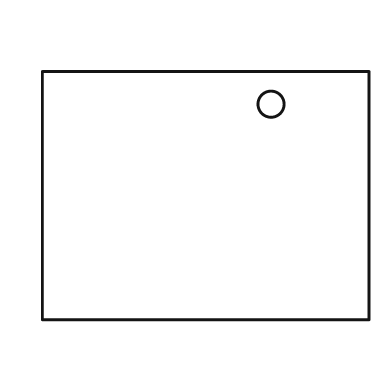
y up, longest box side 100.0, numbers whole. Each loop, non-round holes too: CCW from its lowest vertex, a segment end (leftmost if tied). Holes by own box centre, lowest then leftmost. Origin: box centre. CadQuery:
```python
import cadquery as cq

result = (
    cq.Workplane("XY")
    .moveTo(-50.0, -38.0)
    .lineTo(50.0, -38.0)
    .lineTo(50.0, 38.0)
    .lineTo(-50.0, 38.0)
    .close()
    .moveTo(20.0, 28.0)
    .circle(4.0)
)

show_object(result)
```